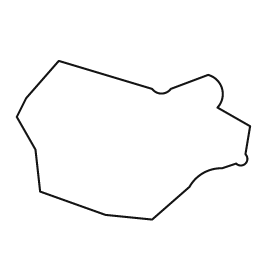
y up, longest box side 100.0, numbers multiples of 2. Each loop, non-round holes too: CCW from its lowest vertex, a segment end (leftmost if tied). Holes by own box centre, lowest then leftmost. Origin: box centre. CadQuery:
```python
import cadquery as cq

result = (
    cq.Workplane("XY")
    .moveTo(8.0, -34.0)
    .lineTo(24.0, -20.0)
    .threePointArc((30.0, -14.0), (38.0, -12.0))
    .lineTo(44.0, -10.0)
    .threePointArc((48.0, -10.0), (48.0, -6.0))
    .lineTo(50.0, 6.0)
    .lineTo(36.0, 14.0)
    .threePointArc((38.0, 22.0), (32.0, 28.0))
    .lineTo(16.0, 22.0)
    .threePointArc((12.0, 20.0), (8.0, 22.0))
    .lineTo(-32.0, 34.0)
    .lineTo(-46.0, 18.0)
    .lineTo(-50.0, 10.0)
    .lineTo(-42.0, -4.0)
    .lineTo(-40.0, -22.0)
    .lineTo(-12.0, -32.0)
    .close()
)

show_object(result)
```